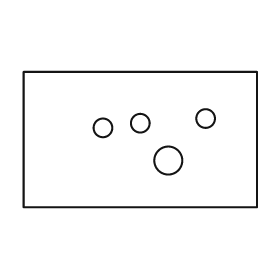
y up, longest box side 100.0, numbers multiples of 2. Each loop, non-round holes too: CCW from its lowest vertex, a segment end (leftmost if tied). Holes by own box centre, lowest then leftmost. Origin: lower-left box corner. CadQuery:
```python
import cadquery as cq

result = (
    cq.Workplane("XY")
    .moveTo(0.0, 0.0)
    .lineTo(100.0, 0.0)
    .lineTo(100.0, 58.0)
    .lineTo(0.0, 58.0)
    .close()
    .moveTo(62.0, 20.0)
    .circle(6.0)
    .moveTo(34.0, 34.0)
    .circle(4.0)
    .moveTo(50.0, 36.0)
    .circle(4.0)
    .moveTo(78.0, 38.0)
    .circle(4.0)
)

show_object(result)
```